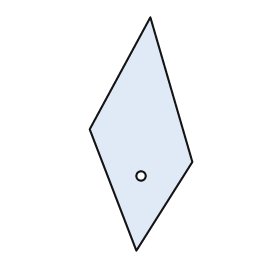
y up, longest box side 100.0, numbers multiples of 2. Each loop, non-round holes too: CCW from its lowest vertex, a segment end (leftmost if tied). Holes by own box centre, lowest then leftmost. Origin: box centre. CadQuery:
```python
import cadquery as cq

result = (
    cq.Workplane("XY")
    .moveTo(-2.0, -50.0)
    .lineTo(22.0, -12.0)
    .lineTo(4.0, 50.0)
    .lineTo(-22.0, 2.0)
    .close()
    .moveTo(0.0, -18.0)
    .circle(2.0)
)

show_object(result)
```